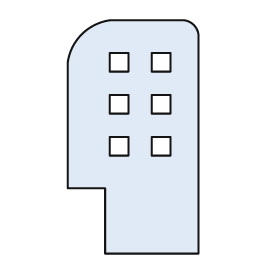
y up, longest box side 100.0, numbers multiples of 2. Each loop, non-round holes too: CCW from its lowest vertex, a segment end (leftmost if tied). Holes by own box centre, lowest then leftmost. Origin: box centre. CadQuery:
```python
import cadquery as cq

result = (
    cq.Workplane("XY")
    .moveTo(-12.0, -50.0)
    .lineTo(28.0, -50.0)
    .lineTo(28.0, 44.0)
    .threePointArc((26.0, 48.0), (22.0, 50.0))
    .lineTo(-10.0, 50.0)
    .threePointArc((-22.0, 44.0), (-28.0, 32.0))
    .lineTo(-28.0, -22.0)
    .lineTo(-12.0, -22.0)
    .close()
    .moveTo(-10.0, -8.0)
    .lineTo(-2.0, -8.0)
    .lineTo(-2.0, 0.0)
    .lineTo(-10.0, 0.0)
    .close()
    .moveTo(8.0, -8.0)
    .lineTo(16.0, -8.0)
    .lineTo(16.0, 0.0)
    .lineTo(8.0, 0.0)
    .close()
    .moveTo(-10.0, 10.0)
    .lineTo(-2.0, 10.0)
    .lineTo(-2.0, 18.0)
    .lineTo(-10.0, 18.0)
    .close()
    .moveTo(8.0, 10.0)
    .lineTo(16.0, 10.0)
    .lineTo(16.0, 18.0)
    .lineTo(8.0, 18.0)
    .close()
    .moveTo(-10.0, 28.0)
    .lineTo(-2.0, 28.0)
    .lineTo(-2.0, 36.0)
    .lineTo(-10.0, 36.0)
    .close()
    .moveTo(8.0, 28.0)
    .lineTo(16.0, 28.0)
    .lineTo(16.0, 36.0)
    .lineTo(8.0, 36.0)
    .close()
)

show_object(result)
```